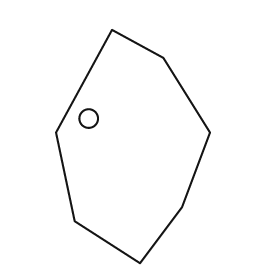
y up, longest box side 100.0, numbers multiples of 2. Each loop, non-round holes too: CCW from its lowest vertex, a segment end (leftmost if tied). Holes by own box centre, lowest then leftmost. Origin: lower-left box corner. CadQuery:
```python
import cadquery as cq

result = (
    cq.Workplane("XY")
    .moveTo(36.0, 0.0)
    .lineTo(54.0, 24.0)
    .lineTo(66.0, 56.0)
    .lineTo(46.0, 88.0)
    .lineTo(24.0, 100.0)
    .lineTo(0.0, 56.0)
    .lineTo(8.0, 18.0)
    .close()
    .moveTo(14.0, 62.0)
    .circle(4.0)
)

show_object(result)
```